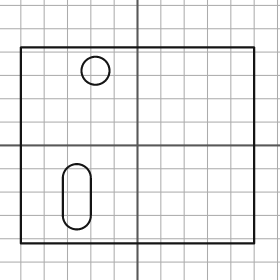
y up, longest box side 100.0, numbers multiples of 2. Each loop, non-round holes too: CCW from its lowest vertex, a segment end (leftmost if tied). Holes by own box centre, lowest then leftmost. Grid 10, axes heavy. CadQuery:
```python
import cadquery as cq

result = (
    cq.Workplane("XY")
    .moveTo(-50.0, -42.0)
    .lineTo(50.0, -42.0)
    .lineTo(50.0, 42.0)
    .lineTo(-50.0, 42.0)
    .close()
    .moveTo(-32.0, -30.0)
    .threePointArc((-26.0, -36.0), (-20.0, -30.0))
    .lineTo(-20.0, -14.0)
    .threePointArc((-26.0, -8.0), (-32.0, -14.0))
    .close()
    .moveTo(-18.0, 32.0)
    .circle(6.0)
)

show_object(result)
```